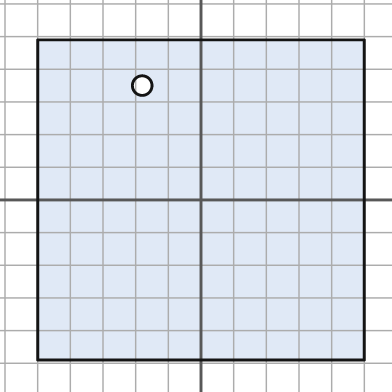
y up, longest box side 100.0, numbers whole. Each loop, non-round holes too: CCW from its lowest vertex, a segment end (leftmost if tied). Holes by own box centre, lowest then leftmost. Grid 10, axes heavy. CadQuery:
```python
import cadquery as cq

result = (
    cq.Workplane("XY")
    .moveTo(-50.0, -49.0)
    .lineTo(50.0, -49.0)
    .lineTo(50.0, 49.0)
    .lineTo(-50.0, 49.0)
    .close()
    .moveTo(-18.0, 35.0)
    .circle(3.0)
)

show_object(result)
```